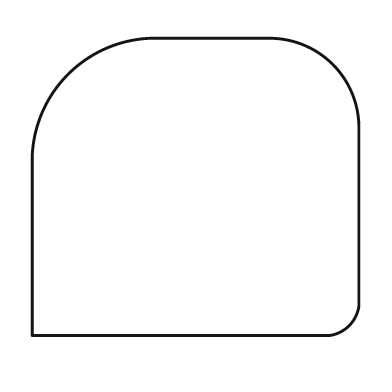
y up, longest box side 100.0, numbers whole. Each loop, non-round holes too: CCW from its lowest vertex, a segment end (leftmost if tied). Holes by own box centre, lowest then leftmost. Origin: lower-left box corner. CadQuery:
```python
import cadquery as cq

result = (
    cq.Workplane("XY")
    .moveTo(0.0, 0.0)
    .lineTo(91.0, 0.0)
    .threePointArc((97.0, 3.0), (100.0, 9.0))
    .lineTo(100.0, 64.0)
    .threePointArc((92.0, 83.0), (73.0, 91.0))
    .lineTo(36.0, 91.0)
    .threePointArc((11.0, 80.0), (0.0, 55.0))
    .close()
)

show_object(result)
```